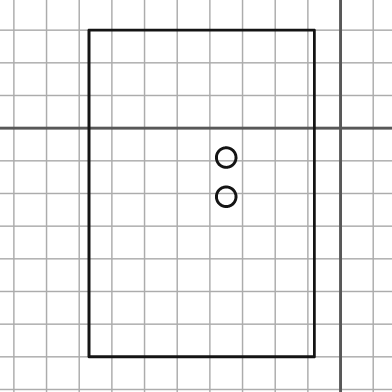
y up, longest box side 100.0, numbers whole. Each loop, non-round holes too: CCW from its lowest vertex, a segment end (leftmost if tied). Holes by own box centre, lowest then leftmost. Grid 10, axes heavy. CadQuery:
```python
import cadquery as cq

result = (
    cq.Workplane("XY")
    .moveTo(-77.0, -70.0)
    .lineTo(-8.0, -70.0)
    .lineTo(-8.0, 30.0)
    .lineTo(-77.0, 30.0)
    .close()
    .moveTo(-35.0, -21.0)
    .circle(3.0)
    .moveTo(-35.0, -9.0)
    .circle(3.0)
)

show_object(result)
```